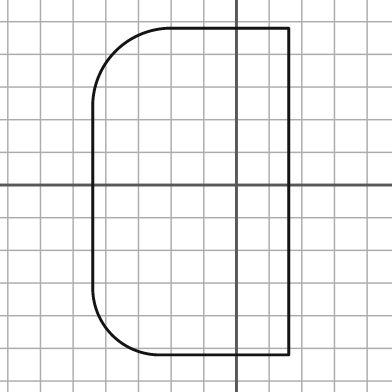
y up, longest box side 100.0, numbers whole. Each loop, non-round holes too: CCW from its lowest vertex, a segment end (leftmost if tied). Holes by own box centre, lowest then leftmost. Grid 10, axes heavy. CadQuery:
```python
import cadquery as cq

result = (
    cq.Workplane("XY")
    .moveTo(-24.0, -52.0)
    .lineTo(16.0, -52.0)
    .lineTo(16.0, 48.0)
    .lineTo(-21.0, 48.0)
    .threePointArc((-37.0, 41.0), (-44.0, 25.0))
    .lineTo(-44.0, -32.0)
    .threePointArc((-38.0, -46.0), (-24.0, -52.0))
    .close()
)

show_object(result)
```